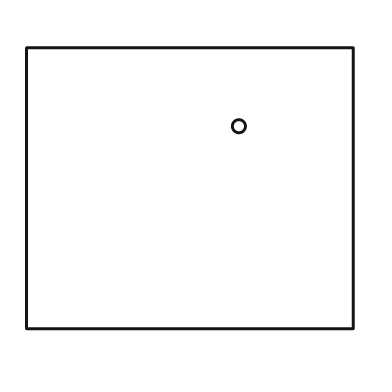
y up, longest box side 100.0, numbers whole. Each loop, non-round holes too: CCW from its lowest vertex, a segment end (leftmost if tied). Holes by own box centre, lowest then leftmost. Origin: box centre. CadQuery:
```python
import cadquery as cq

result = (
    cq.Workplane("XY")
    .moveTo(-50.0, -43.0)
    .lineTo(50.0, -43.0)
    .lineTo(50.0, 43.0)
    .lineTo(-50.0, 43.0)
    .close()
    .moveTo(15.0, 19.0)
    .circle(2.0)
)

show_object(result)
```